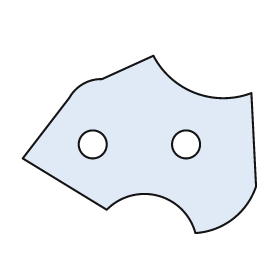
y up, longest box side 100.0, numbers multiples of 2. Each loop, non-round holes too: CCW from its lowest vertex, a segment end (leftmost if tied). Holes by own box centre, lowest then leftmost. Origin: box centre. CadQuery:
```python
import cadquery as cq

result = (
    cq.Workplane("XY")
    .moveTo(24.0, -38.0)
    .threePointArc((40.0, -32.0), (50.0, -18.0))
    .lineTo(48.0, 22.0)
    .threePointArc((24.0, 22.0), (6.0, 38.0))
    .lineTo(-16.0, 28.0)
    .threePointArc((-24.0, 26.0), (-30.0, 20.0))
    .lineTo(-50.0, -6.0)
    .lineTo(-14.0, -28.0)
    .threePointArc((8.0, -22.0), (24.0, -38.0))
    .close()
    .moveTo(-20.0, 0.0)
    .circle(6.0)
    .moveTo(20.0, 0.0)
    .circle(6.0)
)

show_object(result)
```